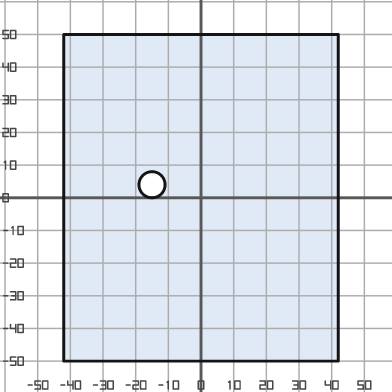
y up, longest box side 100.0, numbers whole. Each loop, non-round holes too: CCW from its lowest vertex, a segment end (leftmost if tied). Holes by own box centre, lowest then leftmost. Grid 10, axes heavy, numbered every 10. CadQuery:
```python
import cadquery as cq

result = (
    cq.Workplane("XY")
    .moveTo(-42.0, -50.0)
    .lineTo(42.0, -50.0)
    .lineTo(42.0, 50.0)
    .lineTo(-42.0, 50.0)
    .close()
    .moveTo(-15.0, 4.0)
    .circle(4.0)
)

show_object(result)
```